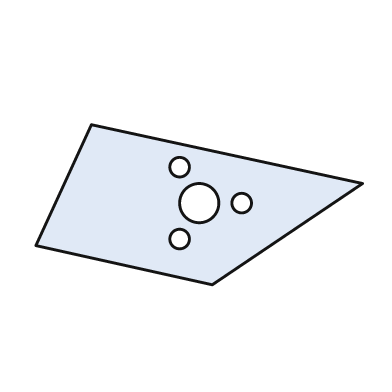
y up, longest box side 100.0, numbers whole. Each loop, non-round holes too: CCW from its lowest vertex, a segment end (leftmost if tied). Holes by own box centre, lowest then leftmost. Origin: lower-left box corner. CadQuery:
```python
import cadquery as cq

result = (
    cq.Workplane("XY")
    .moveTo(54.0, 0.0)
    .lineTo(100.0, 31.0)
    .lineTo(17.0, 49.0)
    .lineTo(0.0, 12.0)
    .close()
    .moveTo(44.0, 14.0)
    .circle(3.0)
    .moveTo(50.0, 25.0)
    .circle(6.0)
    .moveTo(63.0, 25.0)
    .circle(3.0)
    .moveTo(44.0, 36.0)
    .circle(3.0)
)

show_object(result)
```